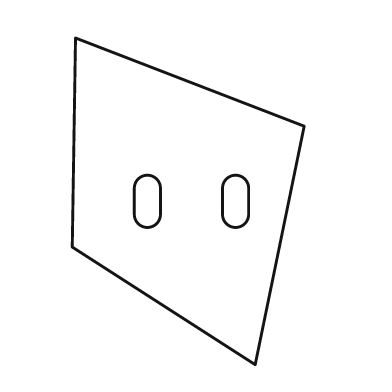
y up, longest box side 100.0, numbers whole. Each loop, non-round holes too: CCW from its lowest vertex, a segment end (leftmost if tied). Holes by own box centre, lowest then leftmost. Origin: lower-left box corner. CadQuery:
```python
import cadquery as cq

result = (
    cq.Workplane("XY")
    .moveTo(56.0, 0.0)
    .lineTo(71.0, 73.0)
    .lineTo(1.0, 100.0)
    .lineTo(0.0, 36.0)
    .close()
    .moveTo(19.0, 46.0)
    .threePointArc((23.0, 42.0), (27.0, 46.0))
    .lineTo(27.0, 54.0)
    .threePointArc((23.0, 58.0), (19.0, 54.0))
    .close()
    .moveTo(46.0, 46.0)
    .threePointArc((50.0, 42.0), (54.0, 46.0))
    .lineTo(54.0, 54.0)
    .threePointArc((50.0, 58.0), (46.0, 54.0))
    .close()
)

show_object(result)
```